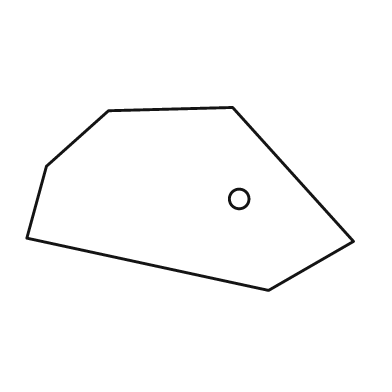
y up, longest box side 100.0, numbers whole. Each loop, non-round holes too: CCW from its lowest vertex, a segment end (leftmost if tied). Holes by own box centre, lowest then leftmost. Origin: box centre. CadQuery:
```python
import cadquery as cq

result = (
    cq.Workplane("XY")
    .moveTo(24.0, -28.0)
    .lineTo(50.0, -13.0)
    .lineTo(13.0, 28.0)
    .lineTo(-25.0, 27.0)
    .lineTo(-44.0, 10.0)
    .lineTo(-50.0, -12.0)
    .close()
    .moveTo(15.0, 0.0)
    .circle(3.0)
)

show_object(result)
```